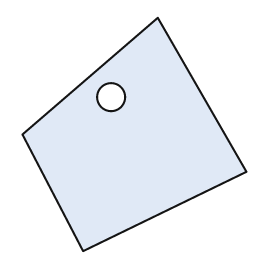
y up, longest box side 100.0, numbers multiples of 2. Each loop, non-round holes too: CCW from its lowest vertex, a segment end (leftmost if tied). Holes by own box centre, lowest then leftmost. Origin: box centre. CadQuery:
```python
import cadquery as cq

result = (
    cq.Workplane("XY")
    .moveTo(-22.0, -50.0)
    .lineTo(48.0, -16.0)
    .lineTo(10.0, 50.0)
    .lineTo(-48.0, 0.0)
    .close()
    .moveTo(-10.0, 16.0)
    .circle(6.0)
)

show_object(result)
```